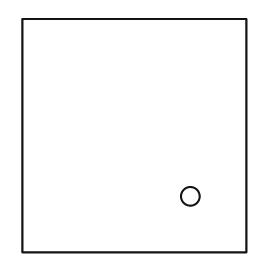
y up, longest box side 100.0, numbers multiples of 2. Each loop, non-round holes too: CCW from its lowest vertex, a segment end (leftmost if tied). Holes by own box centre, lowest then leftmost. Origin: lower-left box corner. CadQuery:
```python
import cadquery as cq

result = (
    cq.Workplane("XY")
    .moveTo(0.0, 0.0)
    .lineTo(96.0, 0.0)
    .lineTo(96.0, 100.0)
    .lineTo(0.0, 100.0)
    .close()
    .moveTo(72.0, 24.0)
    .circle(4.0)
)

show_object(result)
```